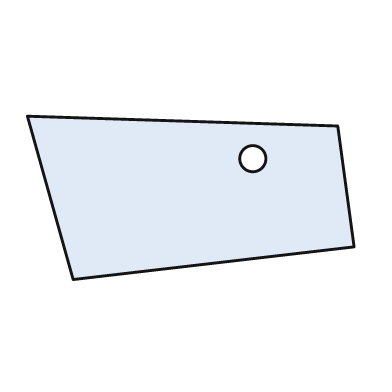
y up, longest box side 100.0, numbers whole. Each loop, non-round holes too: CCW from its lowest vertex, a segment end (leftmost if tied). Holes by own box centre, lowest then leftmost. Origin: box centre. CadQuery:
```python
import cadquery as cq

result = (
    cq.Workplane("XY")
    .moveTo(-36.0, -25.0)
    .lineTo(50.0, -15.0)
    .lineTo(45.0, 22.0)
    .lineTo(-50.0, 25.0)
    .close()
    .moveTo(19.0, 12.0)
    .circle(4.0)
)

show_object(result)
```